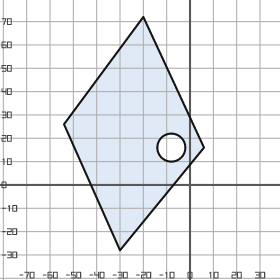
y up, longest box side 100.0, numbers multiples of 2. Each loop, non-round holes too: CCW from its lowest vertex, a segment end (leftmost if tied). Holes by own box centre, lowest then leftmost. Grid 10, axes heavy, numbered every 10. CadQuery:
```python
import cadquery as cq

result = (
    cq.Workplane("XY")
    .moveTo(-30.0, -28.0)
    .lineTo(6.0, 16.0)
    .lineTo(-20.0, 72.0)
    .lineTo(-54.0, 26.0)
    .close()
    .moveTo(-8.0, 16.0)
    .circle(6.0)
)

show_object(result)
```